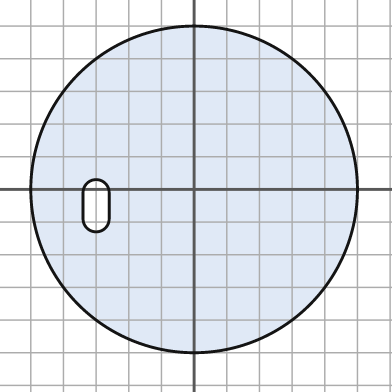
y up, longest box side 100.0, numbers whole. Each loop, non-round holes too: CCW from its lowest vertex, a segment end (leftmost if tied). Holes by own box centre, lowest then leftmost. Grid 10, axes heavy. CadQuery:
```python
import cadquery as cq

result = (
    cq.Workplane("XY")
    .moveTo(0.0, 0.0)
    .circle(50.0)
    .moveTo(-34.0, -9.0)
    .threePointArc((-30.0, -13.0), (-26.0, -9.0))
    .lineTo(-26.0, -1.0)
    .threePointArc((-30.0, 3.0), (-34.0, -1.0))
    .close()
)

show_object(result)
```